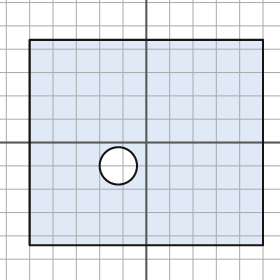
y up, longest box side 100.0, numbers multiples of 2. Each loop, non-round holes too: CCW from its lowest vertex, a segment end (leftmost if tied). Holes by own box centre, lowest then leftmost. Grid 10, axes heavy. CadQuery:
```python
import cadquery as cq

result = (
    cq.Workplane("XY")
    .moveTo(-50.0, -44.0)
    .lineTo(50.0, -44.0)
    .lineTo(50.0, 44.0)
    .lineTo(-50.0, 44.0)
    .close()
    .moveTo(-12.0, -10.0)
    .circle(8.0)
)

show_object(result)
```